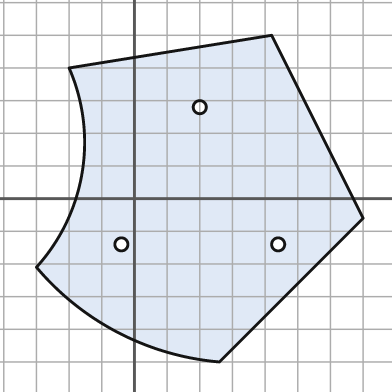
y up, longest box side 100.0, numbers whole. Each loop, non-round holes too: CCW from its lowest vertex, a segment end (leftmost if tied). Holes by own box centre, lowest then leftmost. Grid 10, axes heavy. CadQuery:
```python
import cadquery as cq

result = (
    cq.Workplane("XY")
    .moveTo(26.0, -50.0)
    .lineTo(70.0, -6.0)
    .lineTo(42.0, 50.0)
    .lineTo(-20.0, 40.0)
    .threePointArc((-16.0, 8.0), (-30.0, -21.0))
    .threePointArc((-5.0, -41.0), (26.0, -50.0))
    .close()
    .moveTo(-4.0, -14.0)
    .circle(2.0)
    .moveTo(44.0, -14.0)
    .circle(2.0)
    .moveTo(20.0, 28.0)
    .circle(2.0)
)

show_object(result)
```